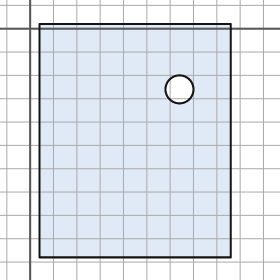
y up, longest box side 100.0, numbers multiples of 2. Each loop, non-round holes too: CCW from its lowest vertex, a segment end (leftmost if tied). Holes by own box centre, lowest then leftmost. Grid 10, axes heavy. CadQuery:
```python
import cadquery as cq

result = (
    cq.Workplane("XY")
    .moveTo(4.0, -98.0)
    .lineTo(86.0, -98.0)
    .lineTo(86.0, 2.0)
    .lineTo(4.0, 2.0)
    .close()
    .moveTo(64.0, -26.0)
    .circle(6.0)
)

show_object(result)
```